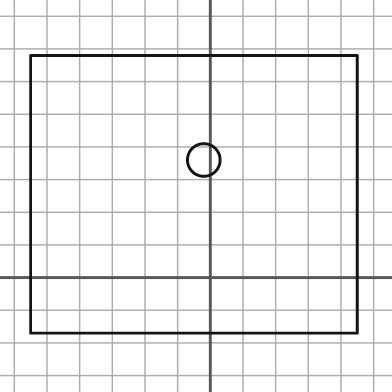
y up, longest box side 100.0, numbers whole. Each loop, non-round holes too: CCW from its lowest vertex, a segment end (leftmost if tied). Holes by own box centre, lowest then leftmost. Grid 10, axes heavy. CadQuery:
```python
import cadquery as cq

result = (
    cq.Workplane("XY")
    .moveTo(-55.0, -17.0)
    .lineTo(45.0, -17.0)
    .lineTo(45.0, 68.0)
    .lineTo(-55.0, 68.0)
    .close()
    .moveTo(-2.0, 36.0)
    .circle(5.0)
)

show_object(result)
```